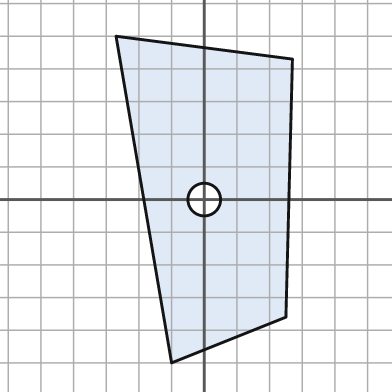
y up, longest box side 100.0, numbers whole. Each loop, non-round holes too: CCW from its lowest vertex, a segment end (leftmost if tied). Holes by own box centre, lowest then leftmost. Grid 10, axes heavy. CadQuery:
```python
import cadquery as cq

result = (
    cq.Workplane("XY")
    .moveTo(-10.0, -50.0)
    .lineTo(25.0, -36.0)
    .lineTo(27.0, 43.0)
    .lineTo(-27.0, 50.0)
    .close()
    .moveTo(0.0, 0.0)
    .circle(5.0)
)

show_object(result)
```